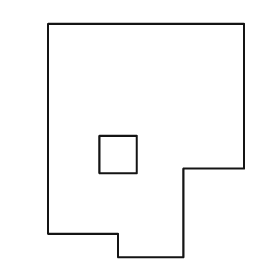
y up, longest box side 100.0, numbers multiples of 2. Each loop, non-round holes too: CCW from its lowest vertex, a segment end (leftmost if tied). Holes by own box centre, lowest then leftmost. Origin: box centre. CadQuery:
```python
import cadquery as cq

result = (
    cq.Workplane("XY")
    .moveTo(-12.0, -50.0)
    .lineTo(16.0, -50.0)
    .lineTo(16.0, -12.0)
    .lineTo(42.0, -12.0)
    .lineTo(42.0, 50.0)
    .lineTo(-42.0, 50.0)
    .lineTo(-42.0, -40.0)
    .lineTo(-12.0, -40.0)
    .close()
    .moveTo(-20.0, -14.0)
    .lineTo(-4.0, -14.0)
    .lineTo(-4.0, 2.0)
    .lineTo(-20.0, 2.0)
    .close()
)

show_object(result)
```